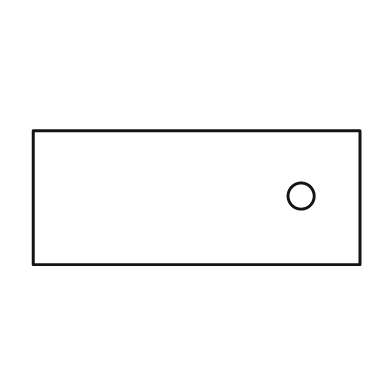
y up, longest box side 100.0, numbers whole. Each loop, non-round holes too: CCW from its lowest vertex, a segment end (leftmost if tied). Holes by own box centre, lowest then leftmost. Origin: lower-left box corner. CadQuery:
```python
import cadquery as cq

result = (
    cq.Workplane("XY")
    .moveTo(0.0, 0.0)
    .lineTo(100.0, 0.0)
    .lineTo(100.0, 41.0)
    .lineTo(0.0, 41.0)
    .close()
    .moveTo(82.0, 21.0)
    .circle(4.0)
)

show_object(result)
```